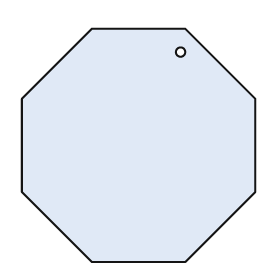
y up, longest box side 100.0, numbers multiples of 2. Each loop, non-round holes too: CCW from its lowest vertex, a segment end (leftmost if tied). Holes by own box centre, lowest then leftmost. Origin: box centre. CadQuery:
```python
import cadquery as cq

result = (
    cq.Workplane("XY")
    .moveTo(-20.0, -50.0)
    .lineTo(20.0, -50.0)
    .lineTo(50.0, -20.0)
    .lineTo(50.0, 20.0)
    .lineTo(20.0, 50.0)
    .lineTo(-20.0, 50.0)
    .lineTo(-50.0, 20.0)
    .lineTo(-50.0, -20.0)
    .close()
    .moveTo(18.0, 40.0)
    .circle(2.0)
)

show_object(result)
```